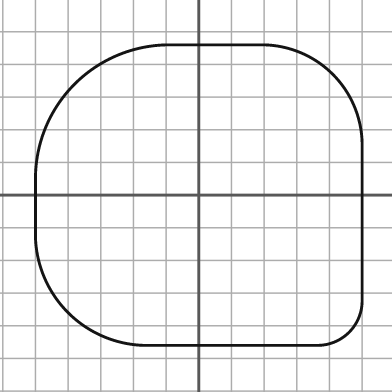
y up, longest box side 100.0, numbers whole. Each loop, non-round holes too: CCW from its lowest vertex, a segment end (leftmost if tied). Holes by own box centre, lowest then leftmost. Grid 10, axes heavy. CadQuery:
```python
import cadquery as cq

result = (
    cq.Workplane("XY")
    .moveTo(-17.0, -46.0)
    .lineTo(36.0, -46.0)
    .threePointArc((46.0, -42.0), (50.0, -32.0))
    .lineTo(50.0, 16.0)
    .threePointArc((41.0, 37.0), (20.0, 46.0))
    .lineTo(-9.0, 46.0)
    .threePointArc((-38.0, 34.0), (-50.0, 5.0))
    .lineTo(-50.0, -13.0)
    .threePointArc((-40.0, -36.0), (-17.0, -46.0))
    .close()
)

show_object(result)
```